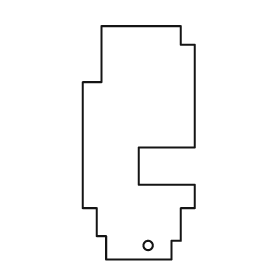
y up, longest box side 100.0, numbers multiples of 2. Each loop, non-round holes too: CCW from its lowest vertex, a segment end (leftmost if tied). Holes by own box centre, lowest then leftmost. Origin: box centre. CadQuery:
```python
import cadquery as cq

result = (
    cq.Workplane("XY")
    .moveTo(-14.0, -50.0)
    .lineTo(14.0, -50.0)
    .lineTo(14.0, -42.0)
    .lineTo(18.0, -42.0)
    .lineTo(18.0, -28.0)
    .lineTo(24.0, -28.0)
    .lineTo(24.0, -18.0)
    .lineTo(0.0, -18.0)
    .lineTo(0.0, -2.0)
    .lineTo(24.0, -2.0)
    .lineTo(24.0, 42.0)
    .lineTo(18.0, 42.0)
    .lineTo(18.0, 50.0)
    .lineTo(-16.0, 50.0)
    .lineTo(-16.0, 26.0)
    .lineTo(-24.0, 26.0)
    .lineTo(-24.0, -28.0)
    .lineTo(-18.0, -28.0)
    .lineTo(-18.0, -40.0)
    .lineTo(-14.0, -40.0)
    .close()
    .moveTo(4.0, -44.0)
    .circle(2.0)
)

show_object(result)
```